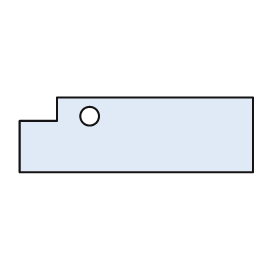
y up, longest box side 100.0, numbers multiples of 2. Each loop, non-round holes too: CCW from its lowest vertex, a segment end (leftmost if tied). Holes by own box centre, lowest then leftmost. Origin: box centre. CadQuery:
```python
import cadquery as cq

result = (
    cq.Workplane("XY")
    .moveTo(-50.0, -16.0)
    .lineTo(50.0, -16.0)
    .lineTo(50.0, 16.0)
    .lineTo(-34.0, 16.0)
    .lineTo(-34.0, 6.0)
    .lineTo(-50.0, 6.0)
    .close()
    .moveTo(-20.0, 8.0)
    .circle(4.0)
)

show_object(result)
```